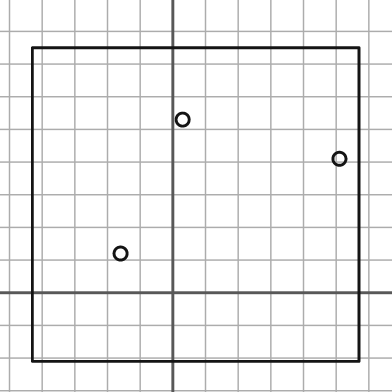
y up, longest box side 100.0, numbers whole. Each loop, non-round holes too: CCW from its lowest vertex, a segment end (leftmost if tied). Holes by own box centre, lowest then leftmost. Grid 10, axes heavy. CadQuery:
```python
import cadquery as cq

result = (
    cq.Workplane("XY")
    .moveTo(-43.0, -21.0)
    .lineTo(57.0, -21.0)
    .lineTo(57.0, 75.0)
    .lineTo(-43.0, 75.0)
    .close()
    .moveTo(-16.0, 12.0)
    .circle(2.0)
    .moveTo(51.0, 41.0)
    .circle(2.0)
    .moveTo(3.0, 53.0)
    .circle(2.0)
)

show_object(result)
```